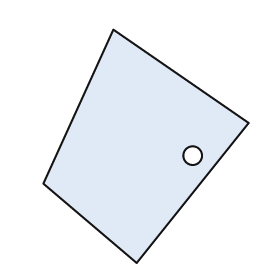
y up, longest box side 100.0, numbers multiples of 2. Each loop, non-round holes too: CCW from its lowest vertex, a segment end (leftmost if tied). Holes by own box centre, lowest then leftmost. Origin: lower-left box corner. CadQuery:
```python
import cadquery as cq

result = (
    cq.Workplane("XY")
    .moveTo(40.0, 0.0)
    .lineTo(88.0, 60.0)
    .lineTo(30.0, 100.0)
    .lineTo(0.0, 34.0)
    .close()
    .moveTo(64.0, 46.0)
    .circle(4.0)
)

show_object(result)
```